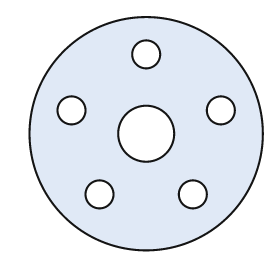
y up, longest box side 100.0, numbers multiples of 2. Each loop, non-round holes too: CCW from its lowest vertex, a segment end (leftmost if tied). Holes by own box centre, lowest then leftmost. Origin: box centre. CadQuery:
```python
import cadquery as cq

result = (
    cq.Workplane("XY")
    .moveTo(0.0, 0.0)
    .circle(50.0)
    .moveTo(-20.0, -26.0)
    .circle(6.0)
    .moveTo(20.0, -26.0)
    .circle(6.0)
    .moveTo(0.0, 0.0)
    .circle(12.0)
    .moveTo(-32.0, 10.0)
    .circle(6.0)
    .moveTo(32.0, 10.0)
    .circle(6.0)
    .moveTo(0.0, 34.0)
    .circle(6.0)
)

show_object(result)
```